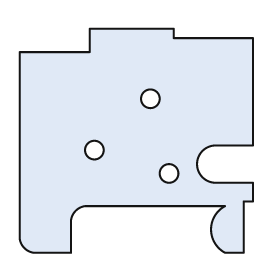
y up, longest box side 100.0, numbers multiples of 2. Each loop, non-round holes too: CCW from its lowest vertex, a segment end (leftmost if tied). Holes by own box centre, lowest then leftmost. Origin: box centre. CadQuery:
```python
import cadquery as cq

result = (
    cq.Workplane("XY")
    .moveTo(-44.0, -48.0)
    .lineTo(-28.0, -48.0)
    .lineTo(-28.0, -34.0)
    .threePointArc((-26.0, -30.0), (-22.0, -28.0))
    .lineTo(38.0, -28.0)
    .threePointArc((32.0, -38.0), (38.0, -48.0))
    .lineTo(46.0, -48.0)
    .lineTo(46.0, -26.0)
    .lineTo(50.0, -26.0)
    .lineTo(50.0, -18.0)
    .lineTo(34.0, -18.0)
    .threePointArc((26.0, -10.0), (34.0, -2.0))
    .lineTo(50.0, -2.0)
    .lineTo(50.0, 44.0)
    .lineTo(16.0, 44.0)
    .lineTo(16.0, 48.0)
    .lineTo(-20.0, 48.0)
    .lineTo(-20.0, 38.0)
    .lineTo(-50.0, 38.0)
    .lineTo(-50.0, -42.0)
    .threePointArc((-48.0, -46.0), (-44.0, -48.0))
    .close()
    .moveTo(14.0, -14.0)
    .circle(4.0)
    .moveTo(-18.0, -4.0)
    .circle(4.0)
    .moveTo(6.0, 18.0)
    .circle(4.0)
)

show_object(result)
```